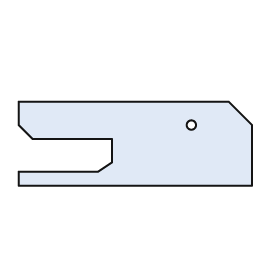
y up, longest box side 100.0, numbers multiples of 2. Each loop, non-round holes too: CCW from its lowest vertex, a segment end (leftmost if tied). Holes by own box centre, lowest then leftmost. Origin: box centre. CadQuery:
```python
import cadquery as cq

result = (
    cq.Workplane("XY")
    .moveTo(-50.0, -18.0)
    .lineTo(50.0, -18.0)
    .lineTo(50.0, 8.0)
    .lineTo(40.0, 18.0)
    .lineTo(-50.0, 18.0)
    .lineTo(-50.0, 8.0)
    .lineTo(-44.0, 2.0)
    .lineTo(-10.0, 2.0)
    .lineTo(-10.0, -8.0)
    .lineTo(-16.0, -12.0)
    .lineTo(-50.0, -12.0)
    .close()
    .moveTo(24.0, 8.0)
    .circle(2.0)
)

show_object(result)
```